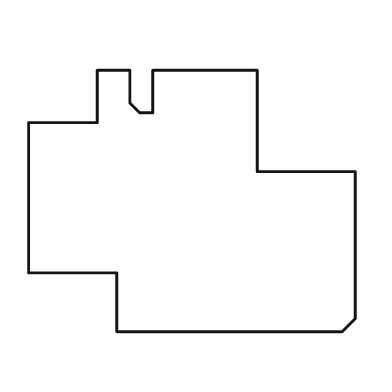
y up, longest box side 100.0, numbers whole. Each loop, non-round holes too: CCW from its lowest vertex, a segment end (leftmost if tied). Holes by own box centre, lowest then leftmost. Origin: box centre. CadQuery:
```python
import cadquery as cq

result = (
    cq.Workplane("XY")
    .moveTo(-23.0, -40.0)
    .lineTo(46.0, -40.0)
    .lineTo(50.0, -36.0)
    .lineTo(50.0, 9.0)
    .lineTo(20.0, 9.0)
    .lineTo(20.0, 40.0)
    .lineTo(-12.0, 40.0)
    .lineTo(-12.0, 27.0)
    .lineTo(-16.0, 27.0)
    .lineTo(-19.0, 30.0)
    .lineTo(-19.0, 40.0)
    .lineTo(-29.0, 40.0)
    .lineTo(-29.0, 24.0)
    .lineTo(-50.0, 24.0)
    .lineTo(-50.0, -22.0)
    .lineTo(-23.0, -22.0)
    .close()
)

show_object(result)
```